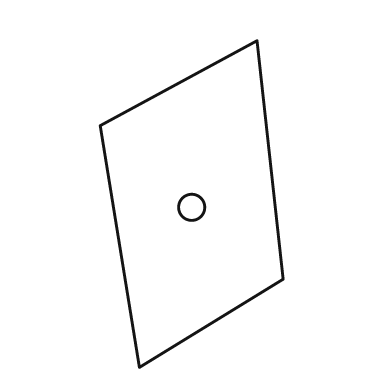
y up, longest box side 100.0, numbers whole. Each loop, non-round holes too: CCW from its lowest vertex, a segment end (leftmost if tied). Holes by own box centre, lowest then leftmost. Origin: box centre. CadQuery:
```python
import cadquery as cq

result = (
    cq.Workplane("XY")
    .moveTo(-16.0, -50.0)
    .lineTo(28.0, -23.0)
    .lineTo(20.0, 50.0)
    .lineTo(-28.0, 24.0)
    .close()
    .moveTo(0.0, -1.0)
    .circle(4.0)
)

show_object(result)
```